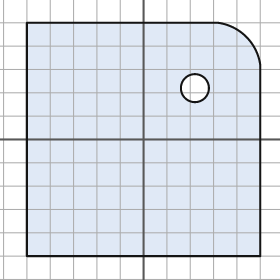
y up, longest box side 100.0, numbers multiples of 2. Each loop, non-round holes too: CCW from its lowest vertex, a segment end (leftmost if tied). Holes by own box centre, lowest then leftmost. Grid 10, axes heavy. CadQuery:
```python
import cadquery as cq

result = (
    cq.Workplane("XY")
    .moveTo(-50.0, -50.0)
    .lineTo(50.0, -50.0)
    .lineTo(50.0, 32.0)
    .threePointArc((44.0, 44.0), (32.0, 50.0))
    .lineTo(-50.0, 50.0)
    .close()
    .moveTo(22.0, 22.0)
    .circle(6.0)
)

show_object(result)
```